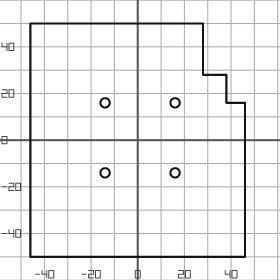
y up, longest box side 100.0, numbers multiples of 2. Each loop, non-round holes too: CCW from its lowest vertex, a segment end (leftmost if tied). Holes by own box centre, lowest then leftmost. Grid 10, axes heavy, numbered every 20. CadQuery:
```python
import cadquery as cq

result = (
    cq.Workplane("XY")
    .moveTo(-46.0, -50.0)
    .lineTo(46.0, -50.0)
    .lineTo(46.0, 16.0)
    .lineTo(38.0, 16.0)
    .lineTo(38.0, 28.0)
    .lineTo(28.0, 28.0)
    .lineTo(28.0, 50.0)
    .lineTo(-46.0, 50.0)
    .close()
    .moveTo(-14.0, -14.0)
    .circle(2.0)
    .moveTo(16.0, -14.0)
    .circle(2.0)
    .moveTo(-14.0, 16.0)
    .circle(2.0)
    .moveTo(16.0, 16.0)
    .circle(2.0)
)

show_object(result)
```